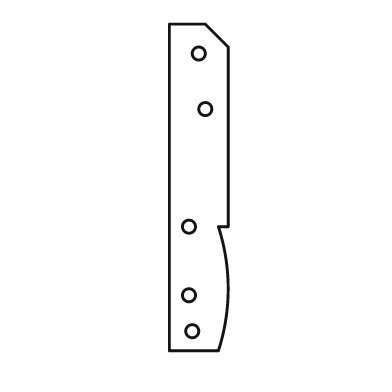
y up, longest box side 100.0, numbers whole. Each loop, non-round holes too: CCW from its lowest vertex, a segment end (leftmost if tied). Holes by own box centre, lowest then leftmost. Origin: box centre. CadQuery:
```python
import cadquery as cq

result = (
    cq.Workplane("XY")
    .moveTo(-9.0, -50.0)
    .lineTo(6.0, -50.0)
    .threePointArc((9.0, -31.0), (6.0, -12.0))
    .lineTo(9.0, -12.0)
    .lineTo(9.0, 43.0)
    .lineTo(2.0, 50.0)
    .lineTo(-9.0, 50.0)
    .close()
    .moveTo(-2.0, -44.0)
    .circle(2.0)
    .moveTo(-3.0, -33.0)
    .circle(2.0)
    .moveTo(-3.0, -12.0)
    .circle(2.0)
    .moveTo(2.0, 24.0)
    .circle(2.0)
    .moveTo(0.0, 41.0)
    .circle(2.0)
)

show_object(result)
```